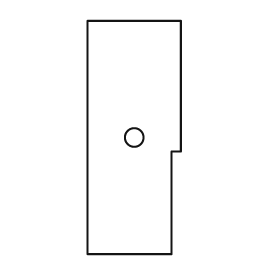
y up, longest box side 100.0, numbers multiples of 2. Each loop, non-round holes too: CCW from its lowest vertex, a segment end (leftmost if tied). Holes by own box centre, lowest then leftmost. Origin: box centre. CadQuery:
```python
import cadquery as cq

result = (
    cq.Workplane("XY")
    .moveTo(-20.0, -50.0)
    .lineTo(16.0, -50.0)
    .lineTo(16.0, -6.0)
    .lineTo(20.0, -6.0)
    .lineTo(20.0, 50.0)
    .lineTo(-20.0, 50.0)
    .close()
    .moveTo(0.0, 0.0)
    .circle(4.0)
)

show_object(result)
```